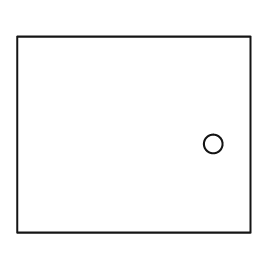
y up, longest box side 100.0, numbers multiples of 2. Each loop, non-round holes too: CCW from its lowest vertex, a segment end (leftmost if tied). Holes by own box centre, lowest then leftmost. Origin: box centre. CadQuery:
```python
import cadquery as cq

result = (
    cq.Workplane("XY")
    .moveTo(-50.0, -42.0)
    .lineTo(50.0, -42.0)
    .lineTo(50.0, 42.0)
    .lineTo(-50.0, 42.0)
    .close()
    .moveTo(34.0, -4.0)
    .circle(4.0)
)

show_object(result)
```